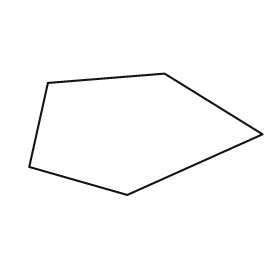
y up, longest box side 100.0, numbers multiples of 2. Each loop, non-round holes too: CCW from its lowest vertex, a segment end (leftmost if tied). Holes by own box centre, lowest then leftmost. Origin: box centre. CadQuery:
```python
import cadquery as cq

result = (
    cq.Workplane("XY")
    .moveTo(-8.0, -26.0)
    .lineTo(50.0, 0.0)
    .lineTo(8.0, 26.0)
    .lineTo(-42.0, 22.0)
    .lineTo(-50.0, -14.0)
    .close()
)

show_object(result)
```